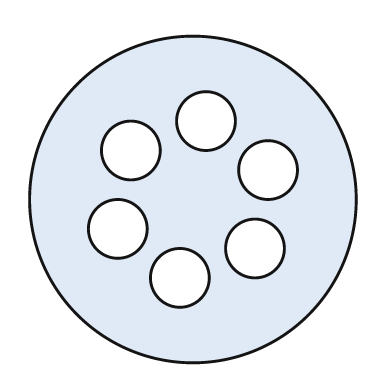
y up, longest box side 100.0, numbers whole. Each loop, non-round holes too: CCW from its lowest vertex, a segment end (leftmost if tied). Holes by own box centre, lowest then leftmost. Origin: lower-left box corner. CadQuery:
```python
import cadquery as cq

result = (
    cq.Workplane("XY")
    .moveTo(50.0, 50.0)
    .circle(50.0)
    .moveTo(46.0, 26.0)
    .circle(9.0)
    .moveTo(69.0, 35.0)
    .circle(9.0)
    .moveTo(27.0, 41.0)
    .circle(9.0)
    .moveTo(73.0, 59.0)
    .circle(9.0)
    .moveTo(31.0, 65.0)
    .circle(9.0)
    .moveTo(54.0, 74.0)
    .circle(9.0)
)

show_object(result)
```